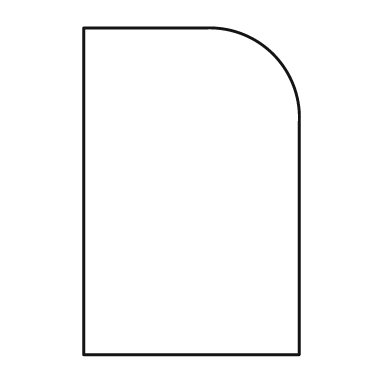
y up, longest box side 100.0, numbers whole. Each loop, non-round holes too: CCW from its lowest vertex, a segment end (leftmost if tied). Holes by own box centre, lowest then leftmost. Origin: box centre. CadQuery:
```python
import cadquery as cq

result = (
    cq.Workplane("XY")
    .moveTo(-33.0, -50.0)
    .lineTo(33.0, -50.0)
    .lineTo(33.0, 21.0)
    .threePointArc((25.0, 42.0), (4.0, 50.0))
    .lineTo(-33.0, 50.0)
    .close()
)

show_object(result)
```